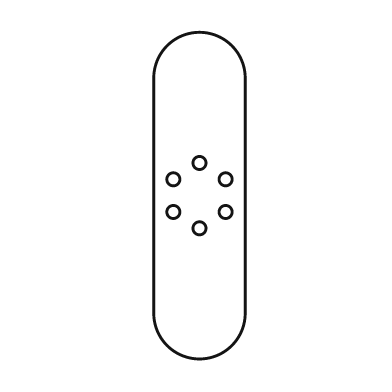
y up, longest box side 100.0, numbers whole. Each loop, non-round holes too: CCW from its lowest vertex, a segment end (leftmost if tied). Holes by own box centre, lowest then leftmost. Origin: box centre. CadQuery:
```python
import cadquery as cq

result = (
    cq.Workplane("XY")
    .moveTo(-14.0, -36.0)
    .threePointArc((0.0, -50.0), (14.0, -36.0))
    .lineTo(14.0, 36.0)
    .threePointArc((0.0, 50.0), (-14.0, 36.0))
    .close()
    .moveTo(0.0, -10.0)
    .circle(2.0)
    .moveTo(-8.0, -5.0)
    .circle(2.0)
    .moveTo(8.0, -5.0)
    .circle(2.0)
    .moveTo(-8.0, 5.0)
    .circle(2.0)
    .moveTo(8.0, 5.0)
    .circle(2.0)
    .moveTo(0.0, 10.0)
    .circle(2.0)
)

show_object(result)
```